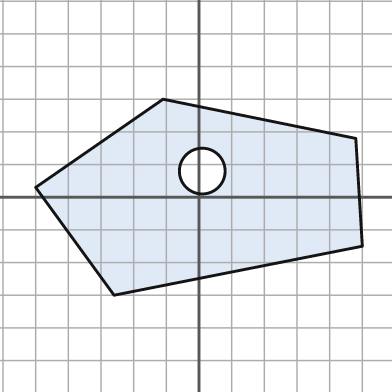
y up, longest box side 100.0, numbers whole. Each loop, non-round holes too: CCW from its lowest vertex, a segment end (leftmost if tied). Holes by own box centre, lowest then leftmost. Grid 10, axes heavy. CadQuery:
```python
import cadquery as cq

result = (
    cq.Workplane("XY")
    .moveTo(-26.0, -30.0)
    .lineTo(50.0, -15.0)
    .lineTo(48.0, 18.0)
    .lineTo(-11.0, 30.0)
    .lineTo(-50.0, 3.0)
    .close()
    .moveTo(1.0, 8.0)
    .circle(7.0)
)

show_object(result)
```